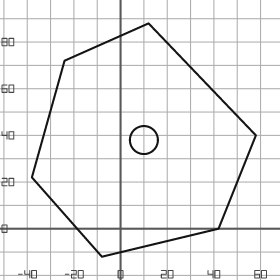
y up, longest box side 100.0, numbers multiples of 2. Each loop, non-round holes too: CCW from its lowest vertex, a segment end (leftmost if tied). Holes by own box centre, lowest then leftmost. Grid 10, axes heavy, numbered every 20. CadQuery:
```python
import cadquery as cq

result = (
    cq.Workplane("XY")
    .moveTo(-8.0, -12.0)
    .lineTo(42.0, 0.0)
    .lineTo(58.0, 40.0)
    .lineTo(12.0, 88.0)
    .lineTo(-24.0, 72.0)
    .lineTo(-38.0, 22.0)
    .close()
    .moveTo(10.0, 38.0)
    .circle(6.0)
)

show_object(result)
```